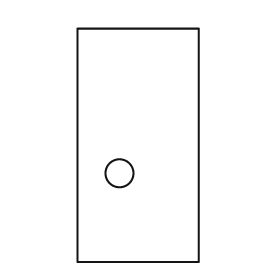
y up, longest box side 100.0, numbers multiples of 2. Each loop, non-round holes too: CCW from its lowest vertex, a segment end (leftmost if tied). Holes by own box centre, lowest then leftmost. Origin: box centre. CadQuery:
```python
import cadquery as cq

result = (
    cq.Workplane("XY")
    .moveTo(-26.0, -50.0)
    .lineTo(26.0, -50.0)
    .lineTo(26.0, 50.0)
    .lineTo(-26.0, 50.0)
    .close()
    .moveTo(-8.0, -12.0)
    .circle(6.0)
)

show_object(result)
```